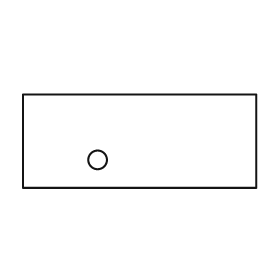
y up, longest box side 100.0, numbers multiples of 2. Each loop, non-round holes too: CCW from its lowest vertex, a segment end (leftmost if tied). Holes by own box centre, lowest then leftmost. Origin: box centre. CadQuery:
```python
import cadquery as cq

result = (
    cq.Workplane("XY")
    .moveTo(-50.0, -20.0)
    .lineTo(50.0, -20.0)
    .lineTo(50.0, 20.0)
    .lineTo(-50.0, 20.0)
    .close()
    .moveTo(-18.0, -8.0)
    .circle(4.0)
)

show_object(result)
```